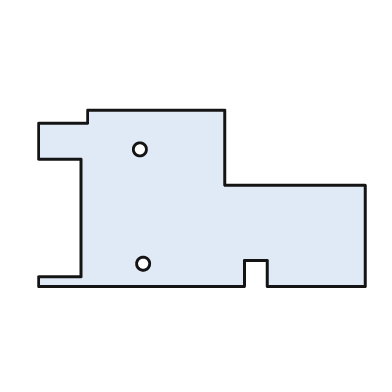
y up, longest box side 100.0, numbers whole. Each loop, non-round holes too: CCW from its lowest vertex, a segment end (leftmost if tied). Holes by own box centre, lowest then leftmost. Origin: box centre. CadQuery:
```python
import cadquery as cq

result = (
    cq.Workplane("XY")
    .moveTo(-50.0, -27.0)
    .lineTo(13.0, -27.0)
    .lineTo(13.0, -19.0)
    .lineTo(20.0, -19.0)
    .lineTo(20.0, -27.0)
    .lineTo(50.0, -27.0)
    .lineTo(50.0, 4.0)
    .lineTo(7.0, 4.0)
    .lineTo(7.0, 27.0)
    .lineTo(-35.0, 27.0)
    .lineTo(-35.0, 23.0)
    .lineTo(-50.0, 23.0)
    .lineTo(-50.0, 12.0)
    .lineTo(-37.0, 12.0)
    .lineTo(-37.0, -24.0)
    .lineTo(-50.0, -24.0)
    .close()
    .moveTo(-18.0, -20.0)
    .circle(2.0)
    .moveTo(-19.0, 15.0)
    .circle(2.0)
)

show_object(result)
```